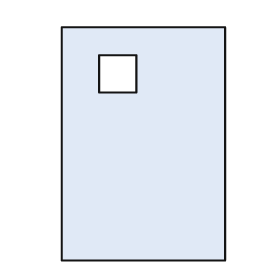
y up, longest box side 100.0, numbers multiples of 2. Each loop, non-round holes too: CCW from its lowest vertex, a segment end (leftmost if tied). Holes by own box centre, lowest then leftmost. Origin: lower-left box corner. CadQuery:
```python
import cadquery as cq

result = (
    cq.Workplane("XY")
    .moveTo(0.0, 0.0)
    .lineTo(70.0, 0.0)
    .lineTo(70.0, 100.0)
    .lineTo(0.0, 100.0)
    .close()
    .moveTo(16.0, 72.0)
    .lineTo(32.0, 72.0)
    .lineTo(32.0, 88.0)
    .lineTo(16.0, 88.0)
    .close()
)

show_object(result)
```